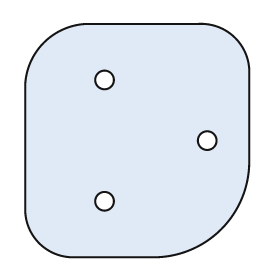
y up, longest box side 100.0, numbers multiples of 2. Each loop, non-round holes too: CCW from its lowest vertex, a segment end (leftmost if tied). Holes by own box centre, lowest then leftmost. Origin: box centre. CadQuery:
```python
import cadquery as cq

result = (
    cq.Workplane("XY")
    .moveTo(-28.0, -50.0)
    .lineTo(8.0, -50.0)
    .threePointArc((36.0, -38.0), (48.0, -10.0))
    .lineTo(48.0, 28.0)
    .threePointArc((42.0, 44.0), (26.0, 50.0))
    .lineTo(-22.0, 50.0)
    .threePointArc((-40.0, 42.0), (-48.0, 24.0))
    .lineTo(-48.0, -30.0)
    .threePointArc((-42.0, -44.0), (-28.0, -50.0))
    .close()
    .moveTo(-14.0, -26.0)
    .circle(4.0)
    .moveTo(30.0, 0.0)
    .circle(4.0)
    .moveTo(-14.0, 26.0)
    .circle(4.0)
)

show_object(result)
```